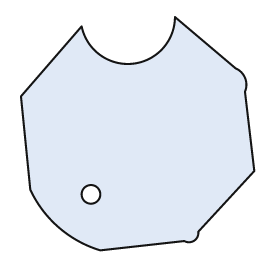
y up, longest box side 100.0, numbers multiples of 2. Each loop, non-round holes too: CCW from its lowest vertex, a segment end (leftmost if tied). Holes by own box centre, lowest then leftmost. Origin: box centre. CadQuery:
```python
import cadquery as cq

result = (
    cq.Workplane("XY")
    .moveTo(-16.0, -50.0)
    .lineTo(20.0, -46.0)
    .threePointArc((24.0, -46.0), (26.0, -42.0))
    .lineTo(50.0, -16.0)
    .lineTo(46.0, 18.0)
    .threePointArc((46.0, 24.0), (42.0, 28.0))
    .lineTo(16.0, 50.0)
    .threePointArc((-2.0, 30.0), (-24.0, 46.0))
    .lineTo(-50.0, 16.0)
    .lineTo(-46.0, -24.0)
    .threePointArc((-34.0, -40.0), (-16.0, -50.0))
    .close()
    .moveTo(-20.0, -26.0)
    .circle(4.0)
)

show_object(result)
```